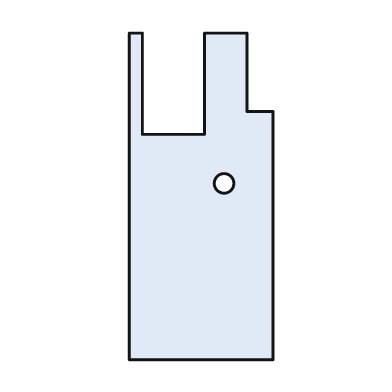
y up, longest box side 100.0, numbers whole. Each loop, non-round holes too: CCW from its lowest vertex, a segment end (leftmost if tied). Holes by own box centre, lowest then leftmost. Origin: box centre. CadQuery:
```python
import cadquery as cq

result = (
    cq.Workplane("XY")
    .moveTo(-22.0, -50.0)
    .lineTo(22.0, -50.0)
    .lineTo(22.0, 26.0)
    .lineTo(14.0, 26.0)
    .lineTo(14.0, 50.0)
    .lineTo(1.0, 50.0)
    .lineTo(1.0, 19.0)
    .lineTo(-18.0, 19.0)
    .lineTo(-18.0, 50.0)
    .lineTo(-22.0, 50.0)
    .close()
    .moveTo(7.0, 4.0)
    .circle(3.0)
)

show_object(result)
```